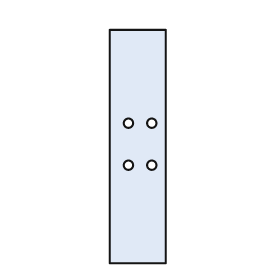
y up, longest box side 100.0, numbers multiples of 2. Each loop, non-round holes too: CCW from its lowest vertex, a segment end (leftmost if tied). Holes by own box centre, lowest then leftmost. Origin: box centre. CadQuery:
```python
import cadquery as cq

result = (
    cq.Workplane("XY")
    .moveTo(-12.0, -50.0)
    .lineTo(12.0, -50.0)
    .lineTo(12.0, 50.0)
    .lineTo(-12.0, 50.0)
    .close()
    .moveTo(-4.0, -8.0)
    .circle(2.0)
    .moveTo(6.0, -8.0)
    .circle(2.0)
    .moveTo(-4.0, 10.0)
    .circle(2.0)
    .moveTo(6.0, 10.0)
    .circle(2.0)
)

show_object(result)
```